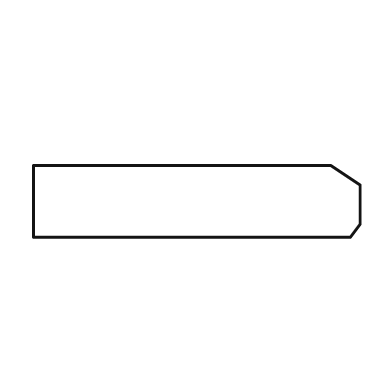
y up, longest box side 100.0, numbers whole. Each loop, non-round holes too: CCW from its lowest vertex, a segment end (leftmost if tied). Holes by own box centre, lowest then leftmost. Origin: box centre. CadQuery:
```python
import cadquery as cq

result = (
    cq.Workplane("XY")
    .moveTo(-50.0, -11.0)
    .lineTo(47.0, -11.0)
    .lineTo(50.0, -7.0)
    .lineTo(50.0, 5.0)
    .lineTo(41.0, 11.0)
    .lineTo(-50.0, 11.0)
    .close()
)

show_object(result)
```